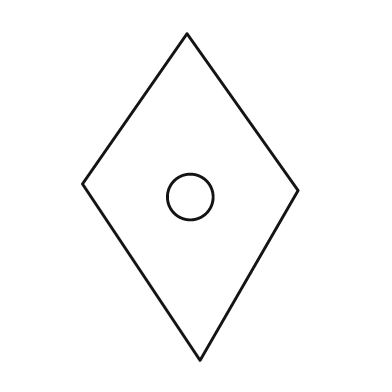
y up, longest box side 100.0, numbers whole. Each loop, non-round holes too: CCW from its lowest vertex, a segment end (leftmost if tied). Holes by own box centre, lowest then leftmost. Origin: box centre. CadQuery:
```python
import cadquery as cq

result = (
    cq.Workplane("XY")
    .moveTo(3.0, -50.0)
    .lineTo(33.0, 2.0)
    .lineTo(-1.0, 50.0)
    .lineTo(-33.0, 4.0)
    .close()
    .moveTo(0.0, 0.0)
    .circle(7.0)
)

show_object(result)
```